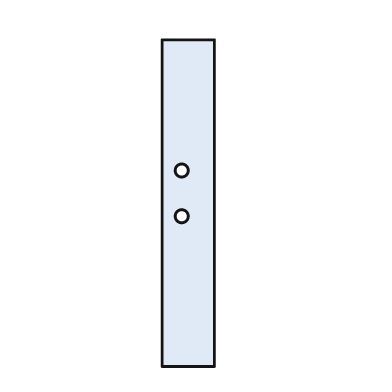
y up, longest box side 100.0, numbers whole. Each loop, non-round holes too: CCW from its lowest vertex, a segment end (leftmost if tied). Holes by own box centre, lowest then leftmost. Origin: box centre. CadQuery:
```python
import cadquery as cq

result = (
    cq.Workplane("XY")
    .moveTo(-8.0, -50.0)
    .lineTo(8.0, -50.0)
    .lineTo(8.0, 50.0)
    .lineTo(-8.0, 50.0)
    .close()
    .moveTo(-2.0, -4.0)
    .circle(2.0)
    .moveTo(-2.0, 10.0)
    .circle(2.0)
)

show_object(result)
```